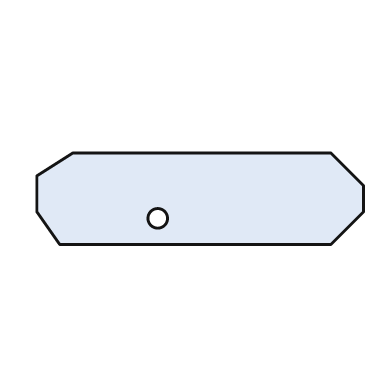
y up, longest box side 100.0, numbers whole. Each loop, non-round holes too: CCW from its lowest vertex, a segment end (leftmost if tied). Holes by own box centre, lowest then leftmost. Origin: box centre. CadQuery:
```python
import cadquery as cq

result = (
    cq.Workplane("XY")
    .moveTo(-43.0, -14.0)
    .lineTo(40.0, -14.0)
    .lineTo(50.0, -4.0)
    .lineTo(50.0, 4.0)
    .lineTo(40.0, 14.0)
    .lineTo(-39.0, 14.0)
    .lineTo(-50.0, 7.0)
    .lineTo(-50.0, -4.0)
    .close()
    .moveTo(-13.0, -6.0)
    .circle(3.0)
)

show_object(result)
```